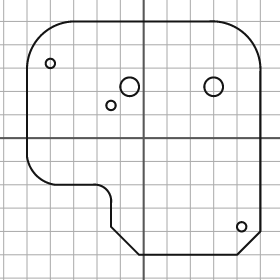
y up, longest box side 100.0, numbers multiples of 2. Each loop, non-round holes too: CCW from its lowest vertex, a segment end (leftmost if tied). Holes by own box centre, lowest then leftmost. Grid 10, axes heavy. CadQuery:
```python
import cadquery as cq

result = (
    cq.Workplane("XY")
    .moveTo(-2.0, -50.0)
    .lineTo(40.0, -50.0)
    .lineTo(50.0, -40.0)
    .lineTo(50.0, 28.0)
    .threePointArc((44.0, 44.0), (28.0, 50.0))
    .lineTo(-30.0, 50.0)
    .threePointArc((-44.0, 44.0), (-50.0, 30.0))
    .lineTo(-50.0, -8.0)
    .threePointArc((-46.0, -16.0), (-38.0, -20.0))
    .lineTo(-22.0, -20.0)
    .threePointArc((-16.0, -22.0), (-14.0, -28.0))
    .lineTo(-14.0, -38.0)
    .close()
    .moveTo(42.0, -38.0)
    .circle(2.0)
    .moveTo(-14.0, 14.0)
    .circle(2.0)
    .moveTo(-6.0, 22.0)
    .circle(4.0)
    .moveTo(30.0, 22.0)
    .circle(4.0)
    .moveTo(-40.0, 32.0)
    .circle(2.0)
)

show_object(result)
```